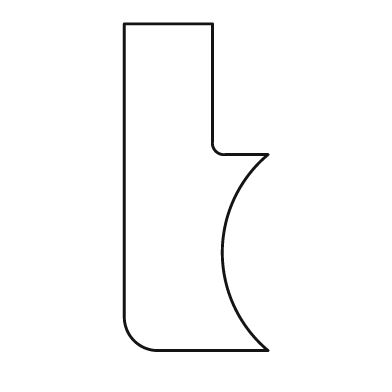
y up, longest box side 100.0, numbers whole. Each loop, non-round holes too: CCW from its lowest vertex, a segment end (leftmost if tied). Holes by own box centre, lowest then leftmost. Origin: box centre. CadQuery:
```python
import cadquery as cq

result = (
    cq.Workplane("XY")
    .moveTo(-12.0, -50.0)
    .lineTo(22.0, -50.0)
    .threePointArc((8.0, -20.0), (22.0, 10.0))
    .lineTo(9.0, 10.0)
    .threePointArc((6.0, 11.0), (5.0, 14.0))
    .lineTo(5.0, 50.0)
    .lineTo(-22.0, 50.0)
    .lineTo(-22.0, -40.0)
    .threePointArc((-19.0, -47.0), (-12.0, -50.0))
    .close()
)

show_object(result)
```